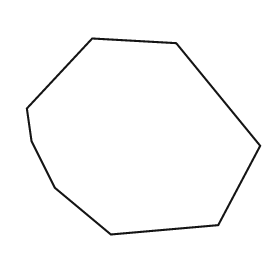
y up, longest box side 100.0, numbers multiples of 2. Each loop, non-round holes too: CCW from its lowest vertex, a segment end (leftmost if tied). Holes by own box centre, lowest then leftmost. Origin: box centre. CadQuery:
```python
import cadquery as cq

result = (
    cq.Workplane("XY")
    .moveTo(-14.0, -42.0)
    .lineTo(32.0, -38.0)
    .lineTo(50.0, -4.0)
    .lineTo(14.0, 40.0)
    .lineTo(-22.0, 42.0)
    .lineTo(-50.0, 12.0)
    .lineTo(-48.0, -2.0)
    .lineTo(-38.0, -22.0)
    .close()
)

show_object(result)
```